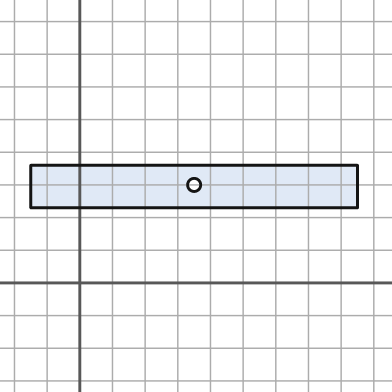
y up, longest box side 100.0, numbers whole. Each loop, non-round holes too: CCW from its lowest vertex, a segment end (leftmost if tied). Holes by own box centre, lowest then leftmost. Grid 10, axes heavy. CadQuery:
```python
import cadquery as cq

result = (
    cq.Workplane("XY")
    .moveTo(-15.0, 23.0)
    .lineTo(85.0, 23.0)
    .lineTo(85.0, 36.0)
    .lineTo(-15.0, 36.0)
    .close()
    .moveTo(35.0, 30.0)
    .circle(2.0)
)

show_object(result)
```